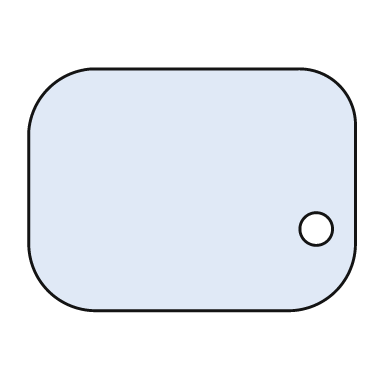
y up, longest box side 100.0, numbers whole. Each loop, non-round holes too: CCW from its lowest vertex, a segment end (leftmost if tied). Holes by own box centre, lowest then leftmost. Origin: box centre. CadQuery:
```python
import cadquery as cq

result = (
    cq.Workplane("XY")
    .moveTo(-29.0, -37.0)
    .lineTo(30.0, -37.0)
    .threePointArc((44.0, -31.0), (50.0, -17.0))
    .lineTo(50.0, 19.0)
    .threePointArc((45.0, 32.0), (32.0, 37.0))
    .lineTo(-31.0, 37.0)
    .threePointArc((-44.0, 31.0), (-50.0, 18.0))
    .lineTo(-50.0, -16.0)
    .threePointArc((-44.0, -31.0), (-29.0, -37.0))
    .close()
    .moveTo(38.0, -12.0)
    .circle(5.0)
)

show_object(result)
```